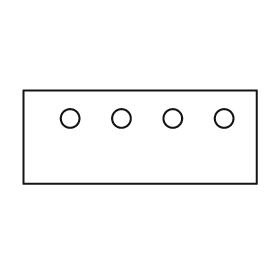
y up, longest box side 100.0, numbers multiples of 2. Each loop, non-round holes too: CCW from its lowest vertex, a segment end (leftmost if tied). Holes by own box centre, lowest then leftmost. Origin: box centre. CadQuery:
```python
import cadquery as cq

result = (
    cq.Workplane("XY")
    .moveTo(-50.0, -20.0)
    .lineTo(50.0, -20.0)
    .lineTo(50.0, 20.0)
    .lineTo(-50.0, 20.0)
    .close()
    .moveTo(-30.0, 8.0)
    .circle(4.0)
    .moveTo(-8.0, 8.0)
    .circle(4.0)
    .moveTo(14.0, 8.0)
    .circle(4.0)
    .moveTo(36.0, 8.0)
    .circle(4.0)
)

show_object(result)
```